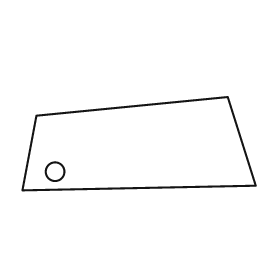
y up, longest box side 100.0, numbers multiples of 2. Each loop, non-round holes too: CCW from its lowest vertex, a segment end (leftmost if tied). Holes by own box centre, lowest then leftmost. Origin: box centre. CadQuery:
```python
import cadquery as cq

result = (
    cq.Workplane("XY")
    .moveTo(-50.0, -20.0)
    .lineTo(50.0, -18.0)
    .lineTo(38.0, 20.0)
    .lineTo(-44.0, 12.0)
    .close()
    .moveTo(-36.0, -12.0)
    .circle(4.0)
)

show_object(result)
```